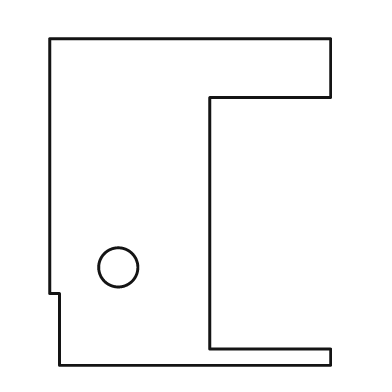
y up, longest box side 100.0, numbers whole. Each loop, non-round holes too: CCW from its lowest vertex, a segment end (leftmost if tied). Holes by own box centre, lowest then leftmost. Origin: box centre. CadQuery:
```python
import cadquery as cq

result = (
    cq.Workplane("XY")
    .moveTo(-40.0, -50.0)
    .lineTo(43.0, -50.0)
    .lineTo(43.0, -45.0)
    .lineTo(6.0, -45.0)
    .lineTo(6.0, 32.0)
    .lineTo(43.0, 32.0)
    .lineTo(43.0, 50.0)
    .lineTo(-43.0, 50.0)
    .lineTo(-43.0, -28.0)
    .lineTo(-40.0, -28.0)
    .close()
    .moveTo(-22.0, -20.0)
    .circle(6.0)
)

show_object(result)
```